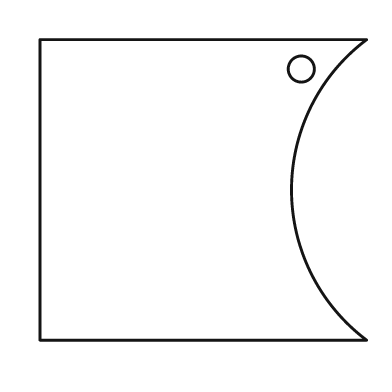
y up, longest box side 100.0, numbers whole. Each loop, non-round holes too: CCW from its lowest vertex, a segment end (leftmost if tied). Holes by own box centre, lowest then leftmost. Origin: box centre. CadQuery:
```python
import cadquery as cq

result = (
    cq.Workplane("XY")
    .moveTo(-50.0, -46.0)
    .lineTo(50.0, -46.0)
    .threePointArc((27.0, 0.0), (50.0, 46.0))
    .lineTo(-50.0, 46.0)
    .close()
    .moveTo(30.0, 37.0)
    .circle(4.0)
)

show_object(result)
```